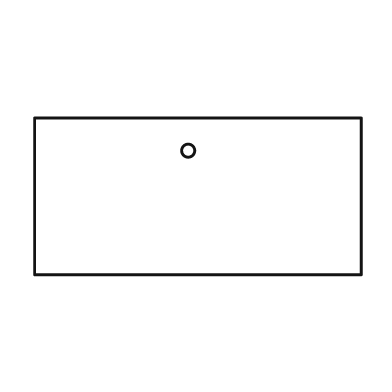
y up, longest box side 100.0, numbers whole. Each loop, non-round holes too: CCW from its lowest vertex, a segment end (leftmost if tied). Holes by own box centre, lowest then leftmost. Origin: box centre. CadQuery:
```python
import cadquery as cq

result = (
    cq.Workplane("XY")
    .moveTo(-50.0, -24.0)
    .lineTo(50.0, -24.0)
    .lineTo(50.0, 24.0)
    .lineTo(-50.0, 24.0)
    .close()
    .moveTo(-3.0, 14.0)
    .circle(2.0)
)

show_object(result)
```